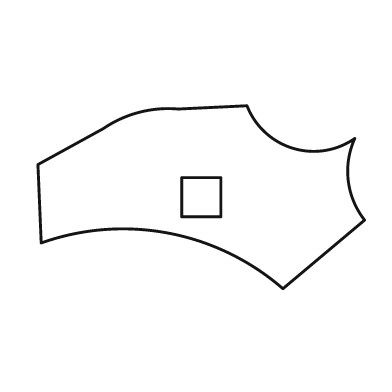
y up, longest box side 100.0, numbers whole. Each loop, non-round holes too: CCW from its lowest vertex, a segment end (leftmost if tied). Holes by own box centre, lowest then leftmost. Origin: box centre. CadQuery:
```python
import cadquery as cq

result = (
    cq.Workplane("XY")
    .moveTo(25.0, -28.0)
    .lineTo(50.0, -7.0)
    .threePointArc((45.0, 5.0), (47.0, 18.0))
    .threePointArc((28.0, 15.0), (14.0, 28.0))
    .lineTo(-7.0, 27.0)
    .threePointArc((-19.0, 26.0), (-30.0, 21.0))
    .lineTo(-50.0, 10.0)
    .lineTo(-49.0, -14.0)
    .threePointArc((-10.0, -11.0), (25.0, -28.0))
    .close()
    .moveTo(-6.0, -6.0)
    .lineTo(6.0, -6.0)
    .lineTo(6.0, 6.0)
    .lineTo(-6.0, 6.0)
    .close()
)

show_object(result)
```